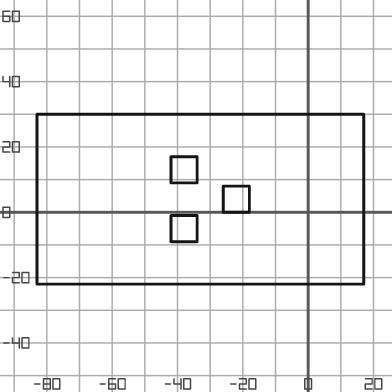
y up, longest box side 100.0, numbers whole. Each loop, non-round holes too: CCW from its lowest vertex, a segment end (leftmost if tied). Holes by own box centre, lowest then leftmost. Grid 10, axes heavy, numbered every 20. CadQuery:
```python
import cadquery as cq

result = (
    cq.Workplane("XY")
    .moveTo(-83.0, -22.0)
    .lineTo(17.0, -22.0)
    .lineTo(17.0, 30.0)
    .lineTo(-83.0, 30.0)
    .close()
    .moveTo(-42.0, -9.0)
    .lineTo(-34.0, -9.0)
    .lineTo(-34.0, -1.0)
    .lineTo(-42.0, -1.0)
    .close()
    .moveTo(-26.0, 0.0)
    .lineTo(-18.0, 0.0)
    .lineTo(-18.0, 8.0)
    .lineTo(-26.0, 8.0)
    .close()
    .moveTo(-42.0, 9.0)
    .lineTo(-34.0, 9.0)
    .lineTo(-34.0, 17.0)
    .lineTo(-42.0, 17.0)
    .close()
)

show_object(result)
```